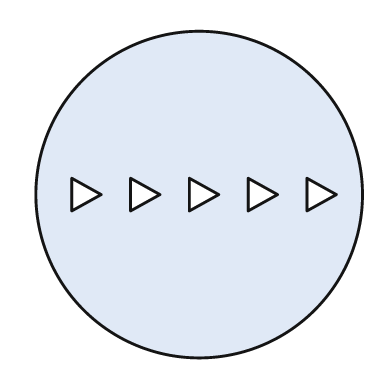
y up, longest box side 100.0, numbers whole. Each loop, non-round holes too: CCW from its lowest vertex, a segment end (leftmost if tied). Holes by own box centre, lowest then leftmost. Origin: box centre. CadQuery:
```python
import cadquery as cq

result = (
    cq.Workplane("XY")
    .moveTo(0.0, 0.0)
    .circle(50.0)
    .moveTo(-39.0, -5.0)
    .lineTo(-30.0, 0.0)
    .lineTo(-39.0, 5.0)
    .close()
    .moveTo(-21.0, -5.0)
    .lineTo(-12.0, 0.0)
    .lineTo(-21.0, 5.0)
    .close()
    .moveTo(-3.0, -5.0)
    .lineTo(6.0, 0.0)
    .lineTo(-3.0, 5.0)
    .close()
    .moveTo(15.0, -5.0)
    .lineTo(24.0, 0.0)
    .lineTo(15.0, 5.0)
    .close()
    .moveTo(33.0, -5.0)
    .lineTo(42.0, 0.0)
    .lineTo(33.0, 5.0)
    .close()
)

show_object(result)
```